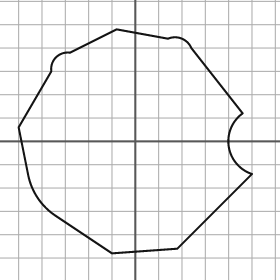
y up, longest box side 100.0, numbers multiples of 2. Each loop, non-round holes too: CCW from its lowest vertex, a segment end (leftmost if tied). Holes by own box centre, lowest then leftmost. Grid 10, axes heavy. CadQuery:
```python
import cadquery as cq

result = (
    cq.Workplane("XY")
    .moveTo(-10.0, -48.0)
    .lineTo(18.0, -46.0)
    .lineTo(50.0, -14.0)
    .threePointArc((40.0, -2.0), (46.0, 12.0))
    .lineTo(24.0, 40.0)
    .threePointArc((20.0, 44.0), (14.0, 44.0))
    .lineTo(-8.0, 48.0)
    .lineTo(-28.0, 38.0)
    .threePointArc((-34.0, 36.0), (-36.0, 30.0))
    .lineTo(-50.0, 6.0)
    .lineTo(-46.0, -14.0)
    .threePointArc((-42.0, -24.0), (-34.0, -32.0))
    .close()
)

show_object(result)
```